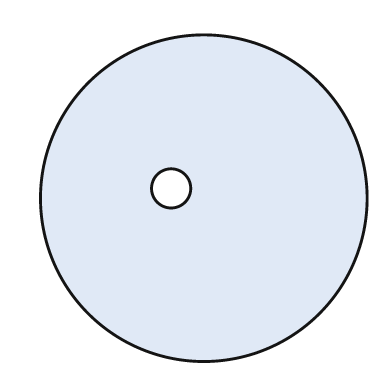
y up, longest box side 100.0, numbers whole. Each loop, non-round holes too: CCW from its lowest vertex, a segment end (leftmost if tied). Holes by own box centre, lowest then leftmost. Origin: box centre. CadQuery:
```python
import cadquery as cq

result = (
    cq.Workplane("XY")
    .moveTo(0.0, 0.0)
    .circle(50.0)
    .moveTo(-10.0, 3.0)
    .circle(6.0)
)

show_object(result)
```